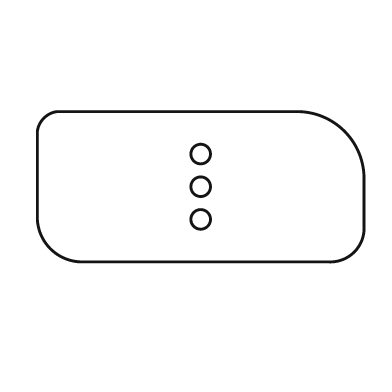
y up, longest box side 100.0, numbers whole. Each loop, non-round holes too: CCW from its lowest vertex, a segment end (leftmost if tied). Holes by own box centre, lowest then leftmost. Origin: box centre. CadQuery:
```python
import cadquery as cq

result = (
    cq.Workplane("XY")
    .moveTo(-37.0, -23.0)
    .lineTo(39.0, -23.0)
    .threePointArc((47.0, -20.0), (50.0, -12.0))
    .lineTo(50.0, 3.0)
    .threePointArc((44.0, 17.0), (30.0, 23.0))
    .lineTo(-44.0, 23.0)
    .threePointArc((-48.0, 21.0), (-50.0, 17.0))
    .lineTo(-50.0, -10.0)
    .threePointArc((-46.0, -19.0), (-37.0, -23.0))
    .close()
    .moveTo(0.0, -10.0)
    .circle(3.0)
    .moveTo(0.0, 0.0)
    .circle(3.0)
    .moveTo(0.0, 10.0)
    .circle(3.0)
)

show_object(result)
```